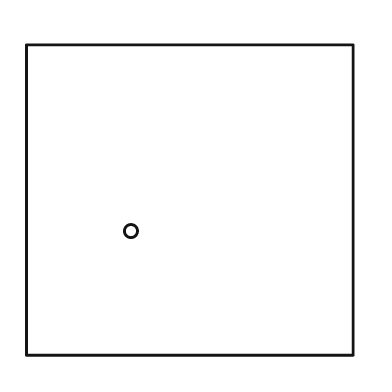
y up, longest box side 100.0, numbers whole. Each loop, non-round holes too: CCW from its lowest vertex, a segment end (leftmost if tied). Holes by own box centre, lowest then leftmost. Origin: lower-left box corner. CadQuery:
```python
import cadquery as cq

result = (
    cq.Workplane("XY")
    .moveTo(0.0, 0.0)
    .lineTo(100.0, 0.0)
    .lineTo(100.0, 95.0)
    .lineTo(0.0, 95.0)
    .close()
    .moveTo(32.0, 38.0)
    .circle(2.0)
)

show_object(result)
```